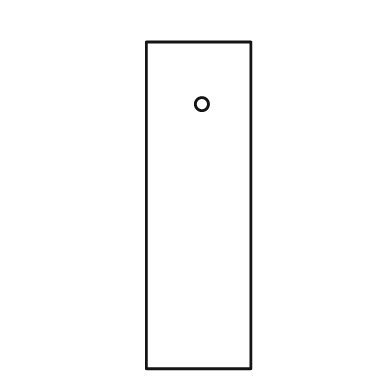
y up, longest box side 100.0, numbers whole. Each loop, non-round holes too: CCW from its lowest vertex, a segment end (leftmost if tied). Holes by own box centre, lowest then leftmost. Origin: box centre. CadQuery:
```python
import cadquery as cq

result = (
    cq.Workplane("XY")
    .moveTo(-16.0, -50.0)
    .lineTo(16.0, -50.0)
    .lineTo(16.0, 50.0)
    .lineTo(-16.0, 50.0)
    .close()
    .moveTo(1.0, 31.0)
    .circle(2.0)
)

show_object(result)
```